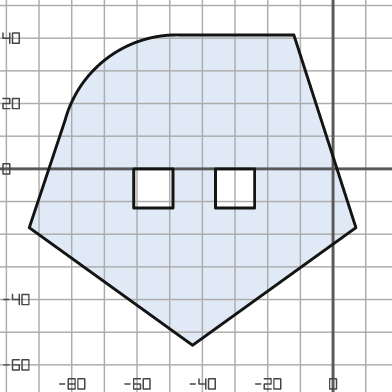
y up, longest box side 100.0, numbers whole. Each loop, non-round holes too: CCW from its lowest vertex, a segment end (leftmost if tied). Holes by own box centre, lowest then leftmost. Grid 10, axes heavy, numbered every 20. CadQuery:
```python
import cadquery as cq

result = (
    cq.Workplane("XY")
    .moveTo(-43.0, -54.0)
    .lineTo(7.0, -18.0)
    .lineTo(-12.0, 41.0)
    .lineTo(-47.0, 41.0)
    .threePointArc((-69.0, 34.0), (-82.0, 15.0))
    .lineTo(-93.0, -18.0)
    .close()
    .moveTo(-61.0, -12.0)
    .lineTo(-49.0, -12.0)
    .lineTo(-49.0, 0.0)
    .lineTo(-61.0, 0.0)
    .close()
    .moveTo(-36.0, -12.0)
    .lineTo(-24.0, -12.0)
    .lineTo(-24.0, 0.0)
    .lineTo(-36.0, 0.0)
    .close()
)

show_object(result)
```